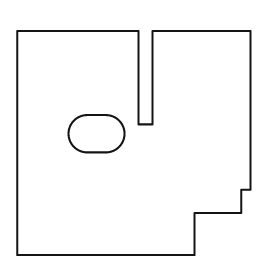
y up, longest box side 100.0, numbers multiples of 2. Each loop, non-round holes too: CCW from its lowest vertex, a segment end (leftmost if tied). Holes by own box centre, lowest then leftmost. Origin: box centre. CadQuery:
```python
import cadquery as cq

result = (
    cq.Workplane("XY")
    .moveTo(-50.0, -48.0)
    .lineTo(26.0, -48.0)
    .lineTo(26.0, -30.0)
    .lineTo(46.0, -30.0)
    .lineTo(46.0, -20.0)
    .lineTo(50.0, -20.0)
    .lineTo(50.0, 48.0)
    .lineTo(8.0, 48.0)
    .lineTo(8.0, 8.0)
    .lineTo(2.0, 8.0)
    .lineTo(2.0, 48.0)
    .lineTo(-50.0, 48.0)
    .close()
    .moveTo(-20.0, -4.0)
    .lineTo(-12.0, -4.0)
    .threePointArc((-4.0, 4.0), (-12.0, 12.0))
    .lineTo(-20.0, 12.0)
    .threePointArc((-28.0, 4.0), (-20.0, -4.0))
    .close()
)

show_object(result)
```